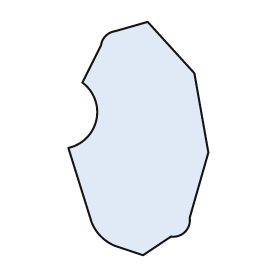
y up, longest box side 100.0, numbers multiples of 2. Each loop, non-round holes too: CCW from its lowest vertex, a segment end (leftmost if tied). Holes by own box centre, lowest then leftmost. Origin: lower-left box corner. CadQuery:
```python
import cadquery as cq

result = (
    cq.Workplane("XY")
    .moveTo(32.0, 0.0)
    .lineTo(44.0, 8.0)
    .threePointArc((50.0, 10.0), (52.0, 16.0))
    .lineTo(60.0, 44.0)
    .lineTo(54.0, 78.0)
    .lineTo(34.0, 100.0)
    .lineTo(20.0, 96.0)
    .threePointArc((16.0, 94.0), (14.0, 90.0))
    .lineTo(6.0, 74.0)
    .threePointArc((12.0, 58.0), (0.0, 46.0))
    .lineTo(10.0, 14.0)
    .threePointArc((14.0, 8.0), (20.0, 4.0))
    .close()
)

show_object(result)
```